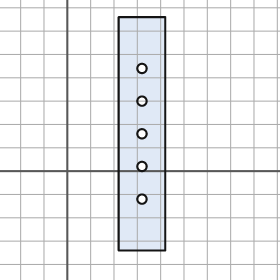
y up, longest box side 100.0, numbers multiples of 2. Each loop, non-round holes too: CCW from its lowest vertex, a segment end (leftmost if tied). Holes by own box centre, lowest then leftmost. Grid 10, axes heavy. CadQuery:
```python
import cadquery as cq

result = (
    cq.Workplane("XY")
    .moveTo(22.0, -34.0)
    .lineTo(42.0, -34.0)
    .lineTo(42.0, 66.0)
    .lineTo(22.0, 66.0)
    .close()
    .moveTo(32.0, -12.0)
    .circle(2.0)
    .moveTo(32.0, 2.0)
    .circle(2.0)
    .moveTo(32.0, 16.0)
    .circle(2.0)
    .moveTo(32.0, 30.0)
    .circle(2.0)
    .moveTo(32.0, 44.0)
    .circle(2.0)
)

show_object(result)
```